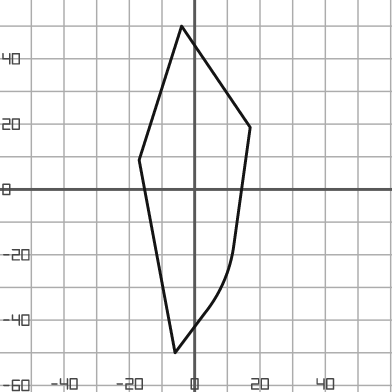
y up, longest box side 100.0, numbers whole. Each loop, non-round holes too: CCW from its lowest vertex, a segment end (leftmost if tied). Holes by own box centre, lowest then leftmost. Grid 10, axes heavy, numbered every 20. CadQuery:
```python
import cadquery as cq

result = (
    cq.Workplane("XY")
    .moveTo(-6.0, -50.0)
    .lineTo(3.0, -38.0)
    .threePointArc((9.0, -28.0), (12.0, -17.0))
    .lineTo(17.0, 19.0)
    .lineTo(-4.0, 50.0)
    .lineTo(-17.0, 9.0)
    .close()
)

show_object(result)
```